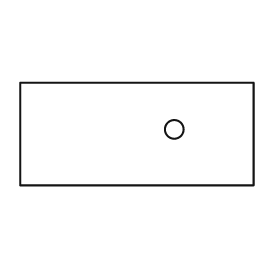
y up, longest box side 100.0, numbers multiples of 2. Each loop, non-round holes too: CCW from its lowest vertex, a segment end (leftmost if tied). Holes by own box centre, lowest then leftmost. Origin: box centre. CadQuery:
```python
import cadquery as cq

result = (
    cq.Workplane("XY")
    .moveTo(-50.0, -22.0)
    .lineTo(50.0, -22.0)
    .lineTo(50.0, 22.0)
    .lineTo(-50.0, 22.0)
    .close()
    .moveTo(16.0, 2.0)
    .circle(4.0)
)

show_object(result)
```